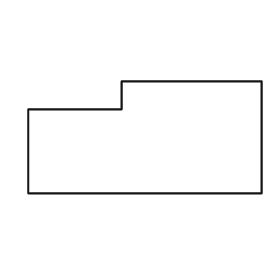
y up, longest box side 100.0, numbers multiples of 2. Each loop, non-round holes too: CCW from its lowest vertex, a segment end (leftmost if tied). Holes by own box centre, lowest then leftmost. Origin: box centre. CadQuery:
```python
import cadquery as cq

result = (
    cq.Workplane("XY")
    .moveTo(-50.0, -24.0)
    .lineTo(50.0, -24.0)
    .lineTo(50.0, 24.0)
    .lineTo(-10.0, 24.0)
    .lineTo(-10.0, 12.0)
    .lineTo(-50.0, 12.0)
    .close()
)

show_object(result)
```